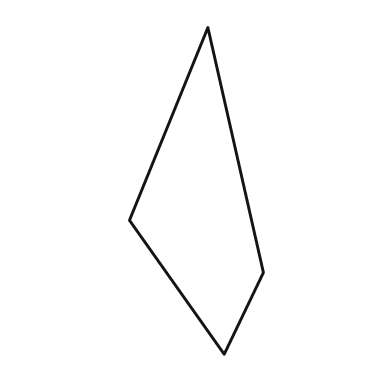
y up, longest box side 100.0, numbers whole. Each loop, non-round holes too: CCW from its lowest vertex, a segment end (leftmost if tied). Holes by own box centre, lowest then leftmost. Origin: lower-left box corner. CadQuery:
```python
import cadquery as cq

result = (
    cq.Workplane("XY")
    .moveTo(29.0, 0.0)
    .lineTo(41.0, 25.0)
    .lineTo(24.0, 100.0)
    .lineTo(0.0, 41.0)
    .close()
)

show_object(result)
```